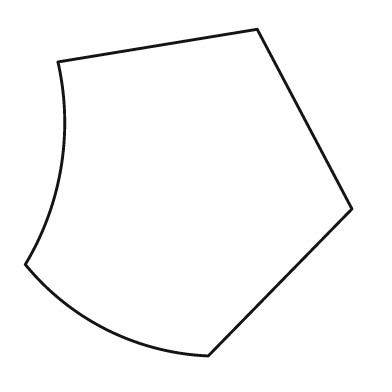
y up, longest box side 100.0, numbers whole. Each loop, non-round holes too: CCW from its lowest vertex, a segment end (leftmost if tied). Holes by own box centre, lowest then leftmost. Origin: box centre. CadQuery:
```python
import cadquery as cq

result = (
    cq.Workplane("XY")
    .moveTo(6.0, -50.0)
    .lineTo(50.0, -5.0)
    .lineTo(21.0, 50.0)
    .lineTo(-40.0, 40.0)
    .threePointArc((-39.0, 8.0), (-50.0, -22.0))
    .threePointArc((-25.0, -42.0), (6.0, -50.0))
    .close()
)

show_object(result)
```